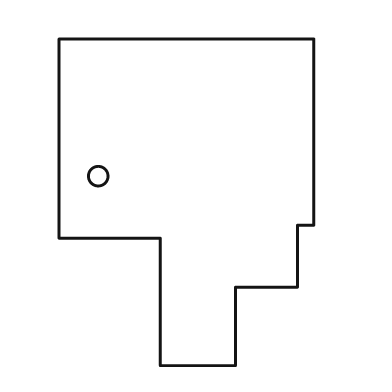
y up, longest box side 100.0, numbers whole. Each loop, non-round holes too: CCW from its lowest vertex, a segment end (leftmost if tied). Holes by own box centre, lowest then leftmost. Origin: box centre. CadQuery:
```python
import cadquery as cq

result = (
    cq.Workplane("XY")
    .moveTo(-8.0, -50.0)
    .lineTo(15.0, -50.0)
    .lineTo(15.0, -26.0)
    .lineTo(34.0, -26.0)
    .lineTo(34.0, -7.0)
    .lineTo(39.0, -7.0)
    .lineTo(39.0, 50.0)
    .lineTo(-39.0, 50.0)
    .lineTo(-39.0, -11.0)
    .lineTo(-8.0, -11.0)
    .close()
    .moveTo(-27.0, 8.0)
    .circle(3.0)
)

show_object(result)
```